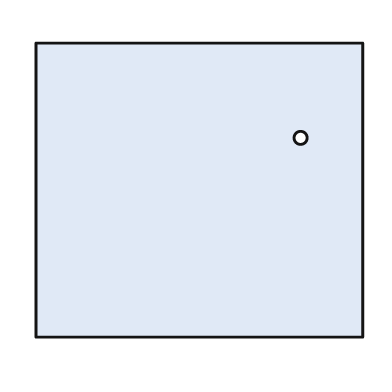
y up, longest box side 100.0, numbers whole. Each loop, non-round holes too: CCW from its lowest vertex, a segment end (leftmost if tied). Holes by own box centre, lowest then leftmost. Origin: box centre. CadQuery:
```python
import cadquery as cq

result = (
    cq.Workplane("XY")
    .moveTo(-50.0, -45.0)
    .lineTo(50.0, -45.0)
    .lineTo(50.0, 45.0)
    .lineTo(-50.0, 45.0)
    .close()
    .moveTo(31.0, 16.0)
    .circle(2.0)
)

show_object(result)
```